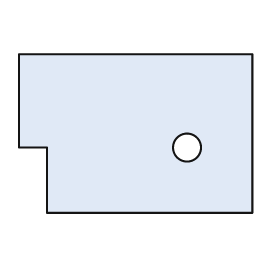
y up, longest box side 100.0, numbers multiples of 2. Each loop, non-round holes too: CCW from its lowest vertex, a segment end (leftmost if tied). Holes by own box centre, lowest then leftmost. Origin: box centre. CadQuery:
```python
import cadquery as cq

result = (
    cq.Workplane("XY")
    .moveTo(-38.0, -34.0)
    .lineTo(50.0, -34.0)
    .lineTo(50.0, 34.0)
    .lineTo(-50.0, 34.0)
    .lineTo(-50.0, -6.0)
    .lineTo(-38.0, -6.0)
    .close()
    .moveTo(22.0, -6.0)
    .circle(6.0)
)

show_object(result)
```